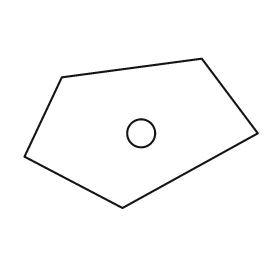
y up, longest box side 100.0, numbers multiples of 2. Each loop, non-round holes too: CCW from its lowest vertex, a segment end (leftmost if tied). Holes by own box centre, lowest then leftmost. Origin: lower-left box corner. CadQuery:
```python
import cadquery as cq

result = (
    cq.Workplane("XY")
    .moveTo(42.0, 0.0)
    .lineTo(100.0, 32.0)
    .lineTo(76.0, 64.0)
    .lineTo(16.0, 56.0)
    .lineTo(0.0, 22.0)
    .close()
    .moveTo(50.0, 32.0)
    .circle(6.0)
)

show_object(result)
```